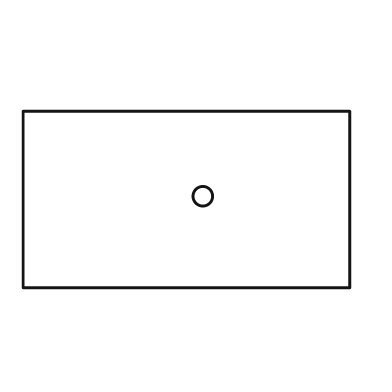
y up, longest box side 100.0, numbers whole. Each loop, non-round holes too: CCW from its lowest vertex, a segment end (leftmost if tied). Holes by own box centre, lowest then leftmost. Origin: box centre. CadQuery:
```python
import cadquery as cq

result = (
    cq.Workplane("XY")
    .moveTo(-50.0, -27.0)
    .lineTo(50.0, -27.0)
    .lineTo(50.0, 27.0)
    .lineTo(-50.0, 27.0)
    .close()
    .moveTo(5.0, 1.0)
    .circle(3.0)
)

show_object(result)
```